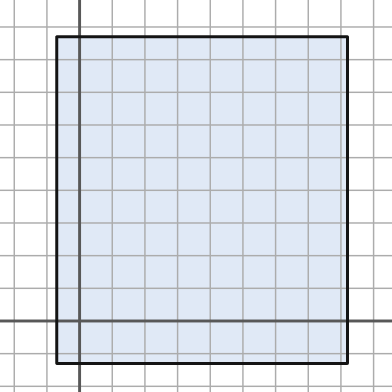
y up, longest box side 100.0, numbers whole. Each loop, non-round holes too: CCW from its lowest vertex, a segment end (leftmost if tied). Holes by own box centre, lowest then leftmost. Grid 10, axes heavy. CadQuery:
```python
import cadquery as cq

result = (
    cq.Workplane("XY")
    .moveTo(-7.0, -13.0)
    .lineTo(82.0, -13.0)
    .lineTo(82.0, 87.0)
    .lineTo(-7.0, 87.0)
    .close()
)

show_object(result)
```